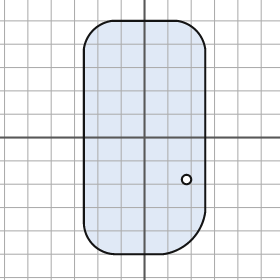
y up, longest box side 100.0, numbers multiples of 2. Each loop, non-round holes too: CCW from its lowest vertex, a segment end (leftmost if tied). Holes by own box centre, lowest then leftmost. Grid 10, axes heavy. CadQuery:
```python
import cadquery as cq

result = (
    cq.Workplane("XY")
    .moveTo(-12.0, -50.0)
    .lineTo(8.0, -50.0)
    .threePointArc((20.0, -44.0), (26.0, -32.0))
    .lineTo(26.0, 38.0)
    .threePointArc((22.0, 46.0), (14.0, 50.0))
    .lineTo(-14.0, 50.0)
    .threePointArc((-22.0, 46.0), (-26.0, 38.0))
    .lineTo(-26.0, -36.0)
    .threePointArc((-22.0, -46.0), (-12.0, -50.0))
    .close()
    .moveTo(18.0, -18.0)
    .circle(2.0)
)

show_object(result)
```